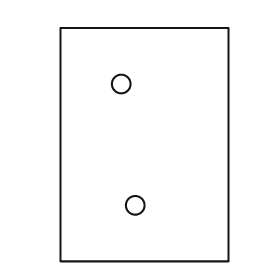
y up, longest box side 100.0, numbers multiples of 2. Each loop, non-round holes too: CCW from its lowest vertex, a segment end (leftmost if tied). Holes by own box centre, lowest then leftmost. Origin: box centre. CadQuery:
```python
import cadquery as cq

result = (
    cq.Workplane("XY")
    .moveTo(-36.0, -50.0)
    .lineTo(36.0, -50.0)
    .lineTo(36.0, 50.0)
    .lineTo(-36.0, 50.0)
    .close()
    .moveTo(-4.0, -26.0)
    .circle(4.0)
    .moveTo(-10.0, 26.0)
    .circle(4.0)
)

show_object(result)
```